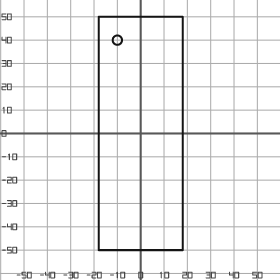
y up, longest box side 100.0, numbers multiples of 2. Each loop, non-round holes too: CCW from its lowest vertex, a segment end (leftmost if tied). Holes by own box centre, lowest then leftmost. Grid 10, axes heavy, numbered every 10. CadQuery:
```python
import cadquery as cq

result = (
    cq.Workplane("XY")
    .moveTo(-18.0, -50.0)
    .lineTo(18.0, -50.0)
    .lineTo(18.0, 50.0)
    .lineTo(-18.0, 50.0)
    .close()
    .moveTo(-10.0, 40.0)
    .circle(2.0)
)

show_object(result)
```